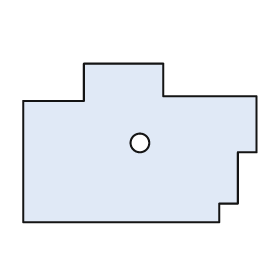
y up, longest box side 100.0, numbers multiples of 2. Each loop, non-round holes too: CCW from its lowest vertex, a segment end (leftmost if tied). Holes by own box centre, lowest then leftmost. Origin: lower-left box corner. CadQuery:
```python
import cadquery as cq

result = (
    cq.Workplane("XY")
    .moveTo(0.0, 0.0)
    .lineTo(84.0, 0.0)
    .lineTo(84.0, 8.0)
    .lineTo(92.0, 8.0)
    .lineTo(92.0, 30.0)
    .lineTo(100.0, 30.0)
    .lineTo(100.0, 54.0)
    .lineTo(60.0, 54.0)
    .lineTo(60.0, 68.0)
    .lineTo(26.0, 68.0)
    .lineTo(26.0, 52.0)
    .lineTo(0.0, 52.0)
    .close()
    .moveTo(50.0, 34.0)
    .circle(4.0)
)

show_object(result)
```